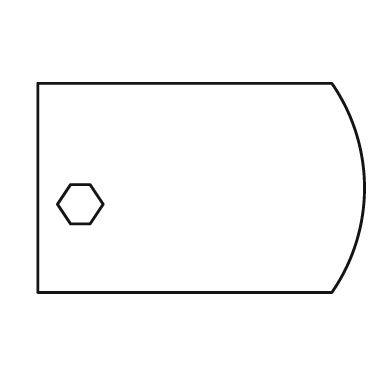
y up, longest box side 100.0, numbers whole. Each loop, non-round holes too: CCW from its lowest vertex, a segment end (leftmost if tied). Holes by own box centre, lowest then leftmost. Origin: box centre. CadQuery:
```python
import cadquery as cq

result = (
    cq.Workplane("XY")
    .moveTo(-50.0, -32.0)
    .lineTo(40.0, -32.0)
    .threePointArc((50.0, 0.0), (40.0, 32.0))
    .lineTo(-50.0, 32.0)
    .close()
    .moveTo(-40.0, -11.0)
    .lineTo(-34.0, -11.0)
    .lineTo(-30.0, -5.0)
    .lineTo(-34.0, 1.0)
    .lineTo(-40.0, 1.0)
    .lineTo(-44.0, -5.0)
    .close()
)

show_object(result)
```